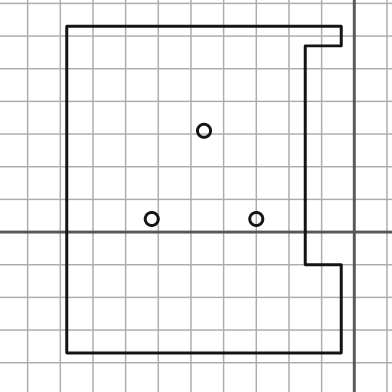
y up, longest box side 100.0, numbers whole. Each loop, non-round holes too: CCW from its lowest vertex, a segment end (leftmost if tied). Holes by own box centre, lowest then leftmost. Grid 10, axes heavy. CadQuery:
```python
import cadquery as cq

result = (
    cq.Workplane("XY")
    .moveTo(-88.0, -37.0)
    .lineTo(-4.0, -37.0)
    .lineTo(-4.0, -10.0)
    .lineTo(-15.0, -10.0)
    .lineTo(-15.0, 57.0)
    .lineTo(-4.0, 57.0)
    .lineTo(-4.0, 63.0)
    .lineTo(-88.0, 63.0)
    .close()
    .moveTo(-62.0, 4.0)
    .circle(2.0)
    .moveTo(-30.0, 4.0)
    .circle(2.0)
    .moveTo(-46.0, 31.0)
    .circle(2.0)
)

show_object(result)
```